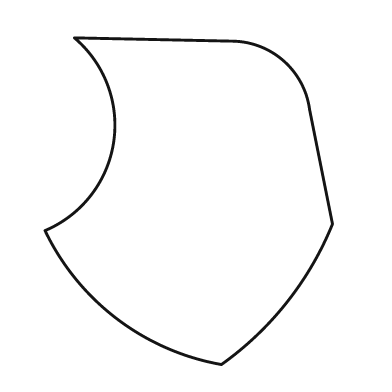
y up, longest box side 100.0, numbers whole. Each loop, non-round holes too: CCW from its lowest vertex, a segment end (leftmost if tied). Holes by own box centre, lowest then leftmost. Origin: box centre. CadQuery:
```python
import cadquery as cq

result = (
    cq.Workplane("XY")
    .moveTo(10.0, -50.0)
    .threePointArc((30.0, -31.0), (44.0, -7.0))
    .lineTo(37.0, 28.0)
    .threePointArc((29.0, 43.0), (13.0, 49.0))
    .lineTo(-35.0, 50.0)
    .threePointArc((-23.0, 18.0), (-44.0, -9.0))
    .threePointArc((-22.0, -36.0), (10.0, -50.0))
    .close()
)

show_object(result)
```